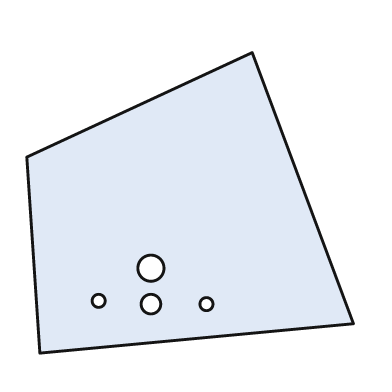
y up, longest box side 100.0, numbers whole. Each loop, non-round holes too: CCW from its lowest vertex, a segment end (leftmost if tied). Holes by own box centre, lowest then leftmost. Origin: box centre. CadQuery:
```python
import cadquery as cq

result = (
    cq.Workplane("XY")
    .moveTo(-46.0, -46.0)
    .lineTo(50.0, -37.0)
    .lineTo(19.0, 46.0)
    .lineTo(-50.0, 14.0)
    .close()
    .moveTo(-12.0, -31.0)
    .circle(3.0)
    .moveTo(5.0, -31.0)
    .circle(2.0)
    .moveTo(-28.0, -30.0)
    .circle(2.0)
    .moveTo(-12.0, -20.0)
    .circle(4.0)
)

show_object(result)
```